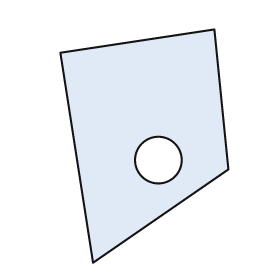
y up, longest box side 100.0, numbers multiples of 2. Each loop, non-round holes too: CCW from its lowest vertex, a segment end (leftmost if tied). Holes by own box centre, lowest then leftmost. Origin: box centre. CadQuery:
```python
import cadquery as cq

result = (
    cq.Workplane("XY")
    .moveTo(-22.0, -50.0)
    .lineTo(36.0, -10.0)
    .lineTo(30.0, 50.0)
    .lineTo(-36.0, 40.0)
    .close()
    .moveTo(6.0, -6.0)
    .circle(10.0)
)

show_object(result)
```